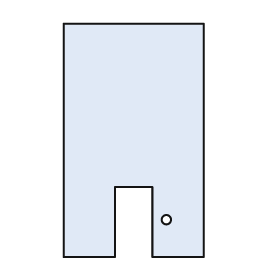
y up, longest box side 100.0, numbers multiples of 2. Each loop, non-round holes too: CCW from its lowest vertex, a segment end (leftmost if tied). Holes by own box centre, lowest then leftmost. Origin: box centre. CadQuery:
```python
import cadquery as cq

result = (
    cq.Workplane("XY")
    .moveTo(-30.0, -50.0)
    .lineTo(-8.0, -50.0)
    .lineTo(-8.0, -20.0)
    .lineTo(8.0, -20.0)
    .lineTo(8.0, -50.0)
    .lineTo(30.0, -50.0)
    .lineTo(30.0, 50.0)
    .lineTo(-30.0, 50.0)
    .close()
    .moveTo(14.0, -34.0)
    .circle(2.0)
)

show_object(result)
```